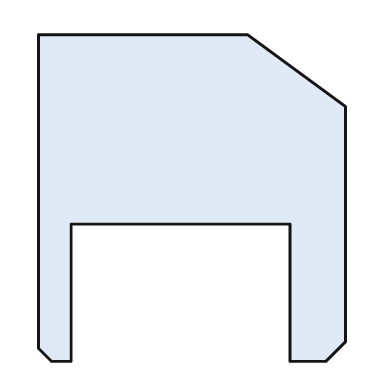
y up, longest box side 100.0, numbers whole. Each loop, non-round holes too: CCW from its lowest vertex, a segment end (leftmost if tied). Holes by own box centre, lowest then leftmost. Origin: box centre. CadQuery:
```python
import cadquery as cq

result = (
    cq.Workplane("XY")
    .moveTo(-43.0, -50.0)
    .lineTo(-37.0, -50.0)
    .lineTo(-37.0, -8.0)
    .lineTo(30.0, -8.0)
    .lineTo(30.0, -50.0)
    .lineTo(41.0, -50.0)
    .lineTo(47.0, -44.0)
    .lineTo(47.0, 28.0)
    .lineTo(17.0, 50.0)
    .lineTo(-47.0, 50.0)
    .lineTo(-47.0, -46.0)
    .close()
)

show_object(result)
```